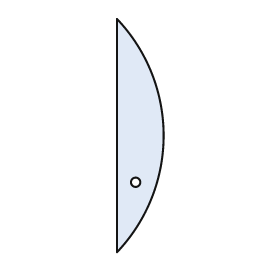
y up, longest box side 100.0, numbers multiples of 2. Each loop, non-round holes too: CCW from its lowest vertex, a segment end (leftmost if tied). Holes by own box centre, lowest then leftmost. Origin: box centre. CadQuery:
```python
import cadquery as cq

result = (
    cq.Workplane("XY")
    .moveTo(-10.0, -50.0)
    .threePointArc((10.0, 0.0), (-10.0, 50.0))
    .close()
    .moveTo(-2.0, -20.0)
    .circle(2.0)
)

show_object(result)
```